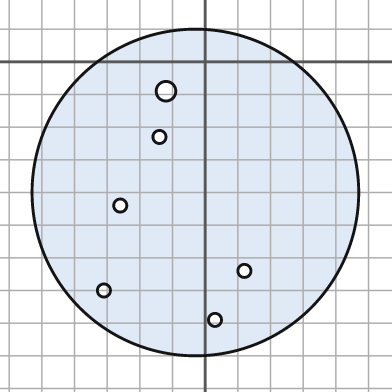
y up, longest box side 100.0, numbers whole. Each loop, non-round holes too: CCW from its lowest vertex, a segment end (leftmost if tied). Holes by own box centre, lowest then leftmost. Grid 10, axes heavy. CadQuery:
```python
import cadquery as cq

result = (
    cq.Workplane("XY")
    .moveTo(-3.0, -40.0)
    .circle(50.0)
    .moveTo(3.0, -79.0)
    .circle(2.0)
    .moveTo(-31.0, -70.0)
    .circle(2.0)
    .moveTo(12.0, -64.0)
    .circle(2.0)
    .moveTo(-26.0, -44.0)
    .circle(2.0)
    .moveTo(-14.0, -23.0)
    .circle(2.0)
    .moveTo(-12.0, -9.0)
    .circle(3.0)
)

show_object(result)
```